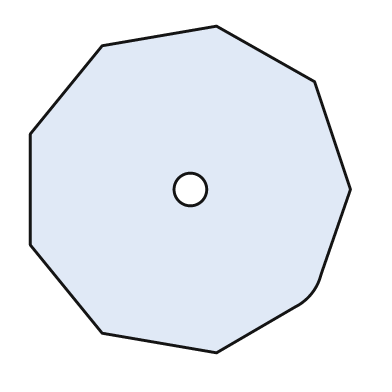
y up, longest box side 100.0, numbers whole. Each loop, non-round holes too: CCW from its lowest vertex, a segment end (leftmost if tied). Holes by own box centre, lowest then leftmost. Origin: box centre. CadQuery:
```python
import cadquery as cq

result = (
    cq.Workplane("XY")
    .moveTo(8.0, -50.0)
    .lineTo(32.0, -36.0)
    .threePointArc((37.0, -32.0), (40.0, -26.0))
    .lineTo(49.0, 0.0)
    .lineTo(38.0, 33.0)
    .lineTo(8.0, 50.0)
    .lineTo(-27.0, 44.0)
    .lineTo(-49.0, 17.0)
    .lineTo(-49.0, -17.0)
    .lineTo(-27.0, -44.0)
    .close()
    .moveTo(0.0, 0.0)
    .circle(5.0)
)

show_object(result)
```